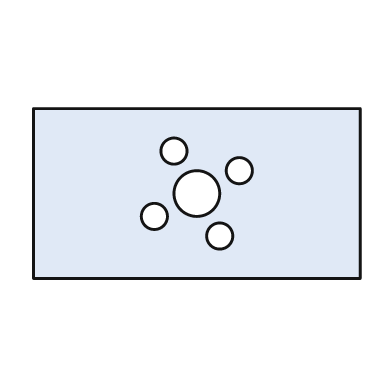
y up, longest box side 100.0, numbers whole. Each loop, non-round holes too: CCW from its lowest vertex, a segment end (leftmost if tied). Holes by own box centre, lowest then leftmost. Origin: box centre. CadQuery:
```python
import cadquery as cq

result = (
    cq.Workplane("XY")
    .moveTo(-50.0, -26.0)
    .lineTo(50.0, -26.0)
    .lineTo(50.0, 26.0)
    .lineTo(-50.0, 26.0)
    .close()
    .moveTo(7.0, -13.0)
    .circle(4.0)
    .moveTo(-13.0, -7.0)
    .circle(4.0)
    .moveTo(0.0, 0.0)
    .circle(7.0)
    .moveTo(13.0, 7.0)
    .circle(4.0)
    .moveTo(-7.0, 13.0)
    .circle(4.0)
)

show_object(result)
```